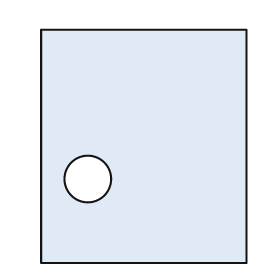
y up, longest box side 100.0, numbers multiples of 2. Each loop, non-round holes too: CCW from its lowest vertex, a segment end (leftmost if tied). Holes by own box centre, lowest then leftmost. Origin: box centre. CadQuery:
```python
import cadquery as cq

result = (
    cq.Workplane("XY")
    .moveTo(-44.0, -50.0)
    .lineTo(44.0, -50.0)
    .lineTo(44.0, 50.0)
    .lineTo(-44.0, 50.0)
    .close()
    .moveTo(-24.0, -14.0)
    .circle(10.0)
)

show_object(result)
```